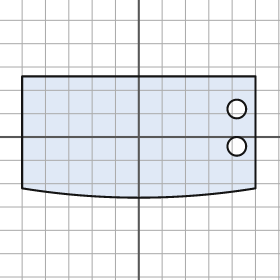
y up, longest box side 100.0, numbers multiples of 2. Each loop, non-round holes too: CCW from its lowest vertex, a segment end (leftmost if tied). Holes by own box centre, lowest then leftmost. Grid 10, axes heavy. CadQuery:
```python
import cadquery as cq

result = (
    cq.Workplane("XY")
    .moveTo(-50.0, -22.0)
    .threePointArc((0.0, -26.0), (50.0, -22.0))
    .lineTo(50.0, 26.0)
    .lineTo(-50.0, 26.0)
    .close()
    .moveTo(42.0, -4.0)
    .circle(4.0)
    .moveTo(42.0, 12.0)
    .circle(4.0)
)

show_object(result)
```